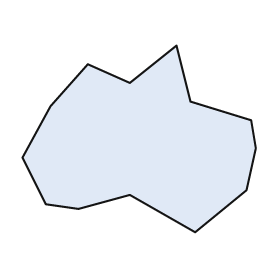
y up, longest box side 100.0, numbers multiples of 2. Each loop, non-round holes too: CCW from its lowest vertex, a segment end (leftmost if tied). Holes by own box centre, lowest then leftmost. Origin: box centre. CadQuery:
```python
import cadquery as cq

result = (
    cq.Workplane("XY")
    .moveTo(24.0, -40.0)
    .lineTo(46.0, -22.0)
    .lineTo(50.0, -4.0)
    .lineTo(48.0, 8.0)
    .lineTo(22.0, 16.0)
    .lineTo(16.0, 40.0)
    .lineTo(-4.0, 24.0)
    .lineTo(-22.0, 32.0)
    .lineTo(-38.0, 14.0)
    .lineTo(-50.0, -8.0)
    .lineTo(-40.0, -28.0)
    .lineTo(-26.0, -30.0)
    .lineTo(-4.0, -24.0)
    .close()
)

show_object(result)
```